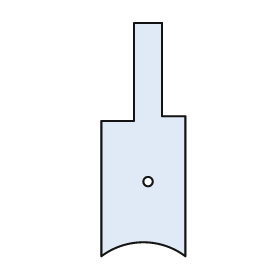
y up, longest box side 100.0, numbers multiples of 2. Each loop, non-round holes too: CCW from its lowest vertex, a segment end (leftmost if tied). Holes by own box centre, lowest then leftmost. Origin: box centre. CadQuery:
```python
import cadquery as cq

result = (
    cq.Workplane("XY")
    .moveTo(-18.0, -50.0)
    .threePointArc((0.0, -44.0), (18.0, -50.0))
    .lineTo(18.0, 10.0)
    .lineTo(8.0, 10.0)
    .lineTo(8.0, 50.0)
    .lineTo(-4.0, 50.0)
    .lineTo(-4.0, 8.0)
    .lineTo(-18.0, 8.0)
    .close()
    .moveTo(2.0, -18.0)
    .circle(2.0)
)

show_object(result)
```